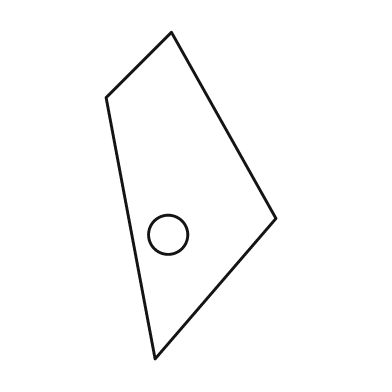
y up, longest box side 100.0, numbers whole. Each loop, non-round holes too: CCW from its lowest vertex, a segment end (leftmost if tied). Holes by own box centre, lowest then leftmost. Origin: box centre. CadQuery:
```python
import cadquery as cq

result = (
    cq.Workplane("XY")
    .moveTo(-11.0, -50.0)
    .lineTo(26.0, -7.0)
    .lineTo(-6.0, 50.0)
    .lineTo(-26.0, 30.0)
    .close()
    .moveTo(-7.0, -12.0)
    .circle(6.0)
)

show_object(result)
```